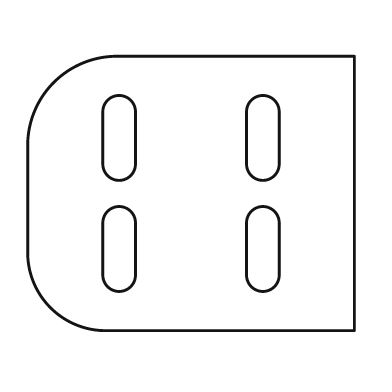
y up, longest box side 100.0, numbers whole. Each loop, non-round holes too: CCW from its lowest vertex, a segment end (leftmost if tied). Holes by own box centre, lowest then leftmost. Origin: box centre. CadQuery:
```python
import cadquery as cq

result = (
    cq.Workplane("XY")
    .moveTo(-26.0, -42.0)
    .lineTo(50.0, -42.0)
    .lineTo(50.0, 42.0)
    .lineTo(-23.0, 42.0)
    .threePointArc((-42.0, 34.0), (-50.0, 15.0))
    .lineTo(-50.0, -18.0)
    .threePointArc((-43.0, -35.0), (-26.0, -42.0))
    .close()
    .moveTo(-27.0, -25.0)
    .threePointArc((-22.0, -30.0), (-17.0, -25.0))
    .lineTo(-17.0, -9.0)
    .threePointArc((-22.0, -4.0), (-27.0, -9.0))
    .close()
    .moveTo(17.0, -25.0)
    .threePointArc((22.0, -30.0), (27.0, -25.0))
    .lineTo(27.0, -9.0)
    .threePointArc((22.0, -4.0), (17.0, -9.0))
    .close()
    .moveTo(-27.0, 9.0)
    .threePointArc((-22.0, 4.0), (-17.0, 9.0))
    .lineTo(-17.0, 25.0)
    .threePointArc((-22.0, 30.0), (-27.0, 25.0))
    .close()
    .moveTo(17.0, 9.0)
    .threePointArc((22.0, 4.0), (27.0, 9.0))
    .lineTo(27.0, 25.0)
    .threePointArc((22.0, 30.0), (17.0, 25.0))
    .close()
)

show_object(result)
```